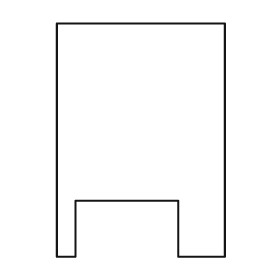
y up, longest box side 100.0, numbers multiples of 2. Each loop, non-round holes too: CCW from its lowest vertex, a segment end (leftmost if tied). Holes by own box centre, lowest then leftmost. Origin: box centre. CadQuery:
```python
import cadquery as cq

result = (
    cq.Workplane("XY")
    .moveTo(-36.0, -50.0)
    .lineTo(-28.0, -50.0)
    .lineTo(-28.0, -26.0)
    .lineTo(16.0, -26.0)
    .lineTo(16.0, -50.0)
    .lineTo(36.0, -50.0)
    .lineTo(36.0, 50.0)
    .lineTo(-36.0, 50.0)
    .close()
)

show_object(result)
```